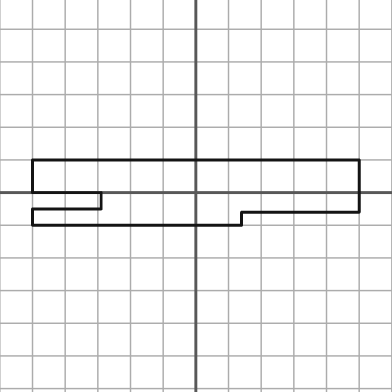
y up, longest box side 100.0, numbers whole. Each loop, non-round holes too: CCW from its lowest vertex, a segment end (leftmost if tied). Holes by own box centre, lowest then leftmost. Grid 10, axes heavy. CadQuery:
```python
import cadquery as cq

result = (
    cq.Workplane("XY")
    .moveTo(-50.0, -10.0)
    .lineTo(14.0, -10.0)
    .lineTo(14.0, -6.0)
    .lineTo(50.0, -6.0)
    .lineTo(50.0, 10.0)
    .lineTo(-50.0, 10.0)
    .lineTo(-50.0, 0.0)
    .lineTo(-29.0, 0.0)
    .lineTo(-29.0, -5.0)
    .lineTo(-50.0, -5.0)
    .close()
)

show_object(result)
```